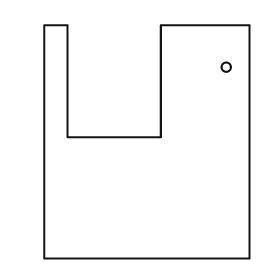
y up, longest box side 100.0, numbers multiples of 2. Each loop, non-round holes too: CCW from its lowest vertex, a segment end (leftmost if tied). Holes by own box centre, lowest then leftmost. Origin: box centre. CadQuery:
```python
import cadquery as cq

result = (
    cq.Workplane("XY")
    .moveTo(-44.0, -50.0)
    .lineTo(44.0, -50.0)
    .lineTo(44.0, 50.0)
    .lineTo(6.0, 50.0)
    .lineTo(6.0, 2.0)
    .lineTo(-34.0, 2.0)
    .lineTo(-34.0, 50.0)
    .lineTo(-44.0, 50.0)
    .close()
    .moveTo(34.0, 32.0)
    .circle(2.0)
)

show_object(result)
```